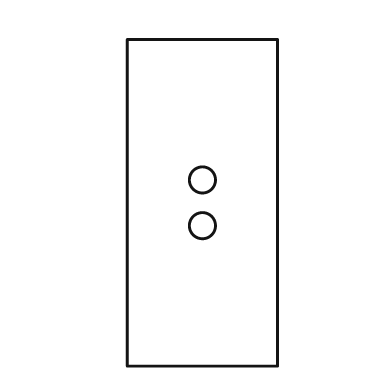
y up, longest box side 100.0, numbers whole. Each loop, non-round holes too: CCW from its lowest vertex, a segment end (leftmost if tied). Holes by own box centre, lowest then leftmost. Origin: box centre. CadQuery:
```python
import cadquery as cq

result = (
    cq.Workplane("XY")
    .moveTo(-23.0, -50.0)
    .lineTo(23.0, -50.0)
    .lineTo(23.0, 50.0)
    .lineTo(-23.0, 50.0)
    .close()
    .moveTo(0.0, -7.0)
    .circle(4.0)
    .moveTo(0.0, 7.0)
    .circle(4.0)
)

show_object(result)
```